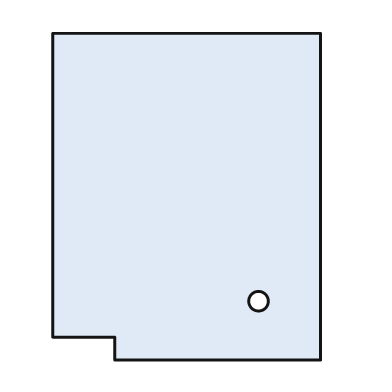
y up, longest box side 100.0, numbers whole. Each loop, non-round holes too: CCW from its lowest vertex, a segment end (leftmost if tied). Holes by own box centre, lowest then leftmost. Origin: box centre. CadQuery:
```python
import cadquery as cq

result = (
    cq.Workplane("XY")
    .moveTo(-22.0, -50.0)
    .lineTo(41.0, -50.0)
    .lineTo(41.0, 50.0)
    .lineTo(-41.0, 50.0)
    .lineTo(-41.0, -43.0)
    .lineTo(-22.0, -43.0)
    .close()
    .moveTo(22.0, -32.0)
    .circle(3.0)
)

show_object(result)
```